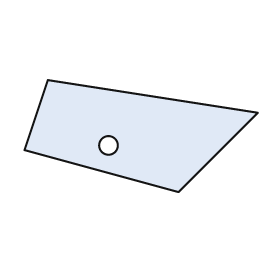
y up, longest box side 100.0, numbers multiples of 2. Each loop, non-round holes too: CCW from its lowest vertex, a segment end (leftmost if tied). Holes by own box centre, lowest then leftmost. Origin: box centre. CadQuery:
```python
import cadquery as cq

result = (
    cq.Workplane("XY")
    .moveTo(16.0, -24.0)
    .lineTo(50.0, 10.0)
    .lineTo(-40.0, 24.0)
    .lineTo(-50.0, -6.0)
    .close()
    .moveTo(-14.0, -4.0)
    .circle(4.0)
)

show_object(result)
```